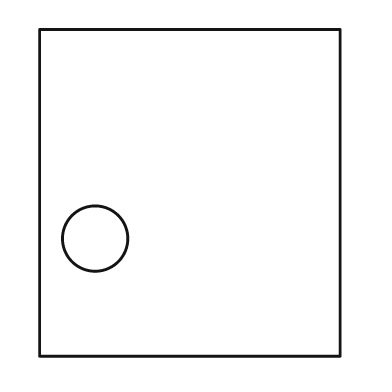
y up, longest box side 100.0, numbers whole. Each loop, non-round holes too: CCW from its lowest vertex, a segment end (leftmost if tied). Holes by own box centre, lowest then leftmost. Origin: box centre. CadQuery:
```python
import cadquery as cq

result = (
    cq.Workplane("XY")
    .moveTo(-46.0, -50.0)
    .lineTo(46.0, -50.0)
    .lineTo(46.0, 50.0)
    .lineTo(-46.0, 50.0)
    .close()
    .moveTo(-29.0, -14.0)
    .circle(10.0)
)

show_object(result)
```